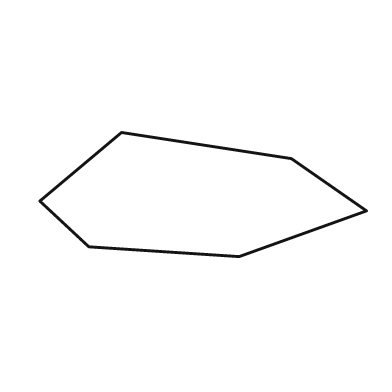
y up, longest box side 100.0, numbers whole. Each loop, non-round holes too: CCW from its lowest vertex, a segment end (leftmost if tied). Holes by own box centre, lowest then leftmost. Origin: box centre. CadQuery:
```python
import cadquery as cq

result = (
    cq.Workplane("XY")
    .moveTo(11.0, -19.0)
    .lineTo(50.0, -5.0)
    .lineTo(27.0, 11.0)
    .lineTo(-25.0, 19.0)
    .lineTo(-50.0, -2.0)
    .lineTo(-35.0, -16.0)
    .close()
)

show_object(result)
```